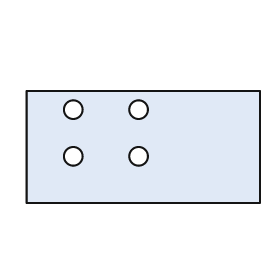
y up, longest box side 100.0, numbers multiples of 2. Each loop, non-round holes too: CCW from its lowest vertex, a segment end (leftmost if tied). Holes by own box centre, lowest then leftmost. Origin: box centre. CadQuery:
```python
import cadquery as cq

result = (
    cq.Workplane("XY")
    .moveTo(-50.0, -24.0)
    .lineTo(50.0, -24.0)
    .lineTo(50.0, 24.0)
    .lineTo(-50.0, 24.0)
    .close()
    .moveTo(-30.0, -4.0)
    .circle(4.0)
    .moveTo(-2.0, -4.0)
    .circle(4.0)
    .moveTo(-30.0, 16.0)
    .circle(4.0)
    .moveTo(-2.0, 16.0)
    .circle(4.0)
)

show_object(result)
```